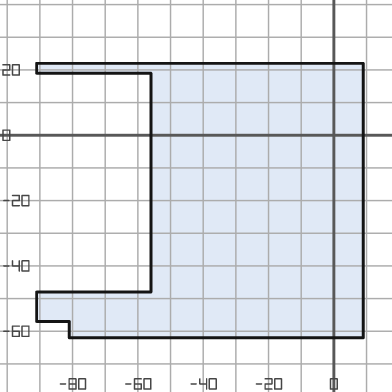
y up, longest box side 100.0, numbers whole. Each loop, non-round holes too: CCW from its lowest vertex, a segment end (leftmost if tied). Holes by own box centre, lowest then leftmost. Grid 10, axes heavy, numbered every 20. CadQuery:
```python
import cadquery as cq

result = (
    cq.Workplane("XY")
    .moveTo(-81.0, -62.0)
    .lineTo(9.0, -62.0)
    .lineTo(9.0, 22.0)
    .lineTo(-91.0, 22.0)
    .lineTo(-91.0, 19.0)
    .lineTo(-56.0, 19.0)
    .lineTo(-56.0, -48.0)
    .lineTo(-91.0, -48.0)
    .lineTo(-91.0, -57.0)
    .lineTo(-81.0, -57.0)
    .close()
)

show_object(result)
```